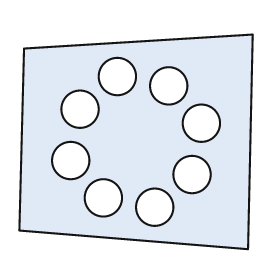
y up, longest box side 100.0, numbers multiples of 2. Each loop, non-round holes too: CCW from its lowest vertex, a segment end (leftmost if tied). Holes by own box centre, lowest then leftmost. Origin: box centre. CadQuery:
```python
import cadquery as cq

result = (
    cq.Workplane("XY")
    .moveTo(48.0, -46.0)
    .lineTo(50.0, 46.0)
    .lineTo(-48.0, 40.0)
    .lineTo(-50.0, -38.0)
    .close()
    .moveTo(8.0, -28.0)
    .circle(8.0)
    .moveTo(-14.0, -24.0)
    .circle(8.0)
    .moveTo(24.0, -14.0)
    .circle(8.0)
    .moveTo(-28.0, -8.0)
    .circle(8.0)
    .moveTo(28.0, 8.0)
    .circle(8.0)
    .moveTo(-24.0, 14.0)
    .circle(8.0)
    .moveTo(14.0, 24.0)
    .circle(8.0)
    .moveTo(-8.0, 28.0)
    .circle(8.0)
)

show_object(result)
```